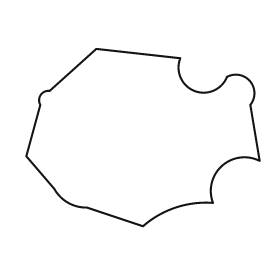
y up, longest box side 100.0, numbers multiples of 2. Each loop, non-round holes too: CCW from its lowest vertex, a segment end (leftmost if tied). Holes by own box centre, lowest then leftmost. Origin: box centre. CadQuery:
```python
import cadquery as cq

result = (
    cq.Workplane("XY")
    .moveTo(0.0, -38.0)
    .threePointArc((14.0, -30.0), (30.0, -28.0))
    .threePointArc((34.0, -12.0), (50.0, -10.0))
    .lineTo(46.0, 14.0)
    .threePointArc((46.0, 24.0), (36.0, 26.0))
    .threePointArc((22.0, 20.0), (16.0, 34.0))
    .lineTo(-20.0, 38.0)
    .lineTo(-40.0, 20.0)
    .threePointArc((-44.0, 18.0), (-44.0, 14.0))
    .lineTo(-50.0, -8.0)
    .lineTo(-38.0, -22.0)
    .threePointArc((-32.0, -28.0), (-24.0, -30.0))
    .close()
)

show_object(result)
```